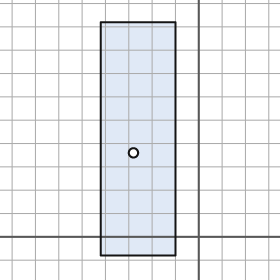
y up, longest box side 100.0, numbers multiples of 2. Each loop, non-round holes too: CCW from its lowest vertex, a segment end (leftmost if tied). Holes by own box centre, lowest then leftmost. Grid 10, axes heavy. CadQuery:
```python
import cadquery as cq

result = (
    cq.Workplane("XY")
    .moveTo(-42.0, -8.0)
    .lineTo(-10.0, -8.0)
    .lineTo(-10.0, 92.0)
    .lineTo(-42.0, 92.0)
    .close()
    .moveTo(-28.0, 36.0)
    .circle(2.0)
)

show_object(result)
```